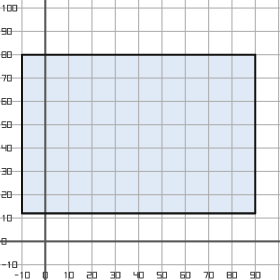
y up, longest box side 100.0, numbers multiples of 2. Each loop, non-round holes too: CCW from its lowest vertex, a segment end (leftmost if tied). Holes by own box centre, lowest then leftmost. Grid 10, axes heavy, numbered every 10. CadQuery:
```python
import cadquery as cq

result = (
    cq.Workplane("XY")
    .moveTo(-10.0, 12.0)
    .lineTo(90.0, 12.0)
    .lineTo(90.0, 80.0)
    .lineTo(-10.0, 80.0)
    .close()
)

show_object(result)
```